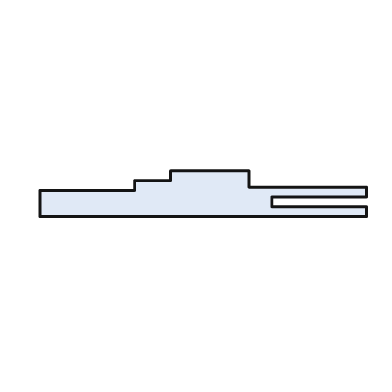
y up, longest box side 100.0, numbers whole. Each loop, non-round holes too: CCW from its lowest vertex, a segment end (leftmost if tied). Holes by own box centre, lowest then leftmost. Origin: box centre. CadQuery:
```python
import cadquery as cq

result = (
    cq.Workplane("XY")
    .moveTo(-50.0, -7.0)
    .lineTo(50.0, -7.0)
    .lineTo(50.0, -4.0)
    .lineTo(21.0, -4.0)
    .lineTo(21.0, -1.0)
    .lineTo(50.0, -1.0)
    .lineTo(50.0, 2.0)
    .lineTo(14.0, 2.0)
    .lineTo(14.0, 7.0)
    .lineTo(-10.0, 7.0)
    .lineTo(-10.0, 4.0)
    .lineTo(-21.0, 4.0)
    .lineTo(-21.0, 1.0)
    .lineTo(-50.0, 1.0)
    .close()
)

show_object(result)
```